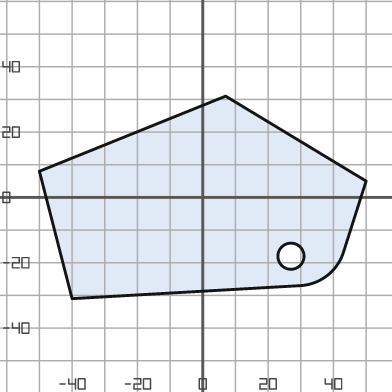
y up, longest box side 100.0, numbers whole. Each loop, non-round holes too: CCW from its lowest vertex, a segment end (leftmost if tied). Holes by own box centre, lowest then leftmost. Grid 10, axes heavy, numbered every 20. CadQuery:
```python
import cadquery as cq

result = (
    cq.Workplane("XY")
    .moveTo(-40.0, -31.0)
    .lineTo(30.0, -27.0)
    .threePointArc((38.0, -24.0), (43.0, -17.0))
    .lineTo(50.0, 5.0)
    .lineTo(7.0, 31.0)
    .lineTo(-50.0, 8.0)
    .close()
    .moveTo(27.0, -18.0)
    .circle(4.0)
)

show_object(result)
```